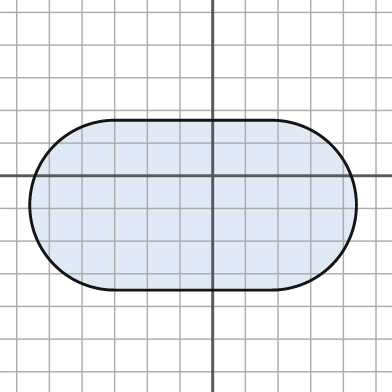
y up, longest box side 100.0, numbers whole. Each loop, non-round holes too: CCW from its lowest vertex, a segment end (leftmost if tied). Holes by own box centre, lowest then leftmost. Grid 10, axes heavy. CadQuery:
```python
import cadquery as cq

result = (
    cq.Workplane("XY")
    .moveTo(-30.0, -35.0)
    .lineTo(18.0, -35.0)
    .threePointArc((44.0, -9.0), (18.0, 17.0))
    .lineTo(-30.0, 17.0)
    .threePointArc((-56.0, -9.0), (-30.0, -35.0))
    .close()
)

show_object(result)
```